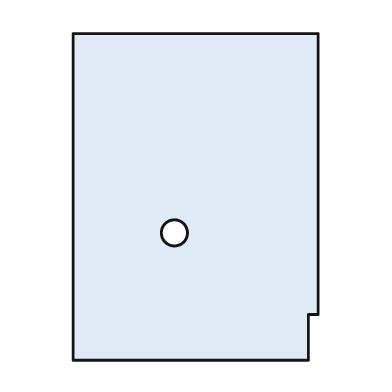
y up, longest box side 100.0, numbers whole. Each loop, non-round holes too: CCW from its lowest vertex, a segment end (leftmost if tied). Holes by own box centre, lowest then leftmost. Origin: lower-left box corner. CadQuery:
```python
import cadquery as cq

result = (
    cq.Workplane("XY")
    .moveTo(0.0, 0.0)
    .lineTo(72.0, 0.0)
    .lineTo(72.0, 14.0)
    .lineTo(75.0, 14.0)
    .lineTo(75.0, 100.0)
    .lineTo(0.0, 100.0)
    .close()
    .moveTo(31.0, 39.0)
    .circle(4.0)
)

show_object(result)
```